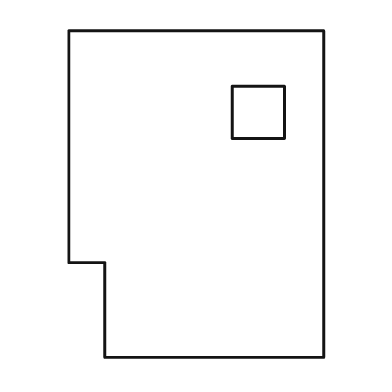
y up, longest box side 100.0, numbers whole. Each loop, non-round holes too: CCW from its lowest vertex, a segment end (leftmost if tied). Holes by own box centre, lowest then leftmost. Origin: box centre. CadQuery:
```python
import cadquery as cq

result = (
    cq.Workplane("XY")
    .moveTo(-28.0, -50.0)
    .lineTo(39.0, -50.0)
    .lineTo(39.0, 50.0)
    .lineTo(-39.0, 50.0)
    .lineTo(-39.0, -21.0)
    .lineTo(-28.0, -21.0)
    .close()
    .moveTo(11.0, 17.0)
    .lineTo(27.0, 17.0)
    .lineTo(27.0, 33.0)
    .lineTo(11.0, 33.0)
    .close()
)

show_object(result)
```